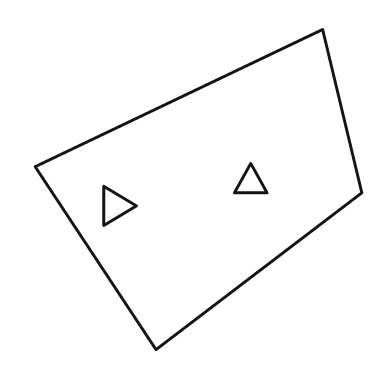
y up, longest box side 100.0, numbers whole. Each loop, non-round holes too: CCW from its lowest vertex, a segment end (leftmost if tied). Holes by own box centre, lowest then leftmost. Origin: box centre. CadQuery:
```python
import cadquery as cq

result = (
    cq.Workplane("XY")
    .moveTo(-13.0, -49.0)
    .lineTo(50.0, -1.0)
    .lineTo(38.0, 49.0)
    .lineTo(-50.0, 7.0)
    .close()
    .moveTo(-29.0, -11.0)
    .lineTo(-19.0, -5.0)
    .lineTo(-29.0, 1.0)
    .close()
    .moveTo(11.0, -1.0)
    .lineTo(21.0, -1.0)
    .lineTo(16.0, 8.0)
    .close()
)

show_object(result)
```